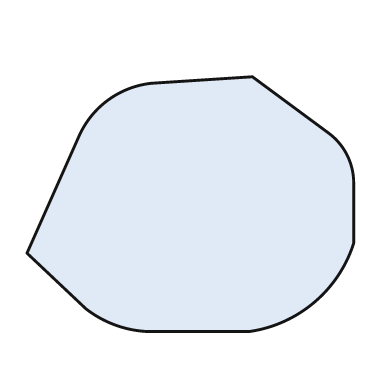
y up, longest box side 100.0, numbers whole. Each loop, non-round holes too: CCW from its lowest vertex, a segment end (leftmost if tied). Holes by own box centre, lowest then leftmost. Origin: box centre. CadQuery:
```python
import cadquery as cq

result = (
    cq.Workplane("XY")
    .moveTo(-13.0, -39.0)
    .lineTo(18.0, -39.0)
    .threePointArc((38.0, -30.0), (50.0, -12.0))
    .lineTo(50.0, 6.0)
    .threePointArc((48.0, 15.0), (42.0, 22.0))
    .lineTo(19.0, 39.0)
    .lineTo(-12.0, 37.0)
    .threePointArc((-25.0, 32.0), (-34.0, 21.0))
    .lineTo(-50.0, -15.0)
    .lineTo(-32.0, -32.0)
    .threePointArc((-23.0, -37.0), (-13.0, -39.0))
    .close()
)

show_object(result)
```